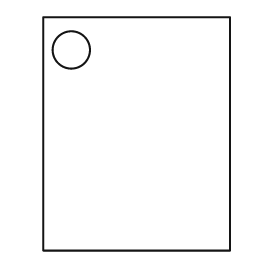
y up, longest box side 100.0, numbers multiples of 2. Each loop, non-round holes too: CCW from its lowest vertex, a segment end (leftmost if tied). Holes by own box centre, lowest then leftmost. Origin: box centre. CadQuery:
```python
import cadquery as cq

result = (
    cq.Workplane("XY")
    .moveTo(-40.0, -50.0)
    .lineTo(40.0, -50.0)
    .lineTo(40.0, 50.0)
    .lineTo(-40.0, 50.0)
    .close()
    .moveTo(-28.0, 36.0)
    .circle(8.0)
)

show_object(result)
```